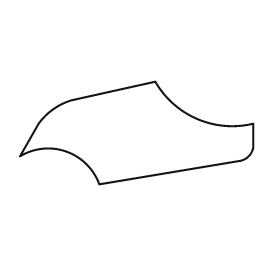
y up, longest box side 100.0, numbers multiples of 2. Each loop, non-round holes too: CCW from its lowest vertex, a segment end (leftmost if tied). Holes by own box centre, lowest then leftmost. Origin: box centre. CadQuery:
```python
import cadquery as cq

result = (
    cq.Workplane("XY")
    .moveTo(-16.0, -22.0)
    .lineTo(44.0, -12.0)
    .threePointArc((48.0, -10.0), (50.0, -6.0))
    .lineTo(50.0, 4.0)
    .threePointArc((26.0, 6.0), (8.0, 22.0))
    .lineTo(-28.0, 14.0)
    .threePointArc((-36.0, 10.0), (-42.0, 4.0))
    .lineTo(-50.0, -10.0)
    .threePointArc((-30.0, -8.0), (-16.0, -22.0))
    .close()
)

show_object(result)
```